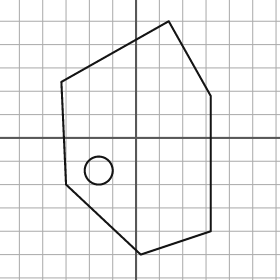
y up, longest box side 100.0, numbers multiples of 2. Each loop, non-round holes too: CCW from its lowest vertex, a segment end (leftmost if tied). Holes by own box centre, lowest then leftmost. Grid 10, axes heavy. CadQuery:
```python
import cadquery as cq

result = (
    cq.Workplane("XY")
    .moveTo(2.0, -50.0)
    .lineTo(32.0, -40.0)
    .lineTo(32.0, 18.0)
    .lineTo(14.0, 50.0)
    .lineTo(-32.0, 24.0)
    .lineTo(-30.0, -20.0)
    .close()
    .moveTo(-16.0, -14.0)
    .circle(6.0)
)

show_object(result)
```